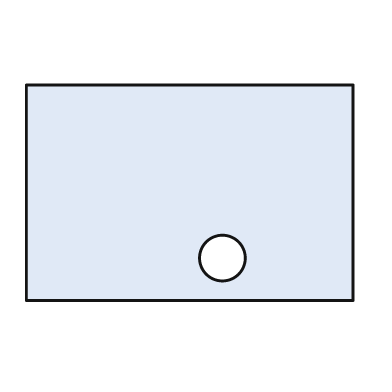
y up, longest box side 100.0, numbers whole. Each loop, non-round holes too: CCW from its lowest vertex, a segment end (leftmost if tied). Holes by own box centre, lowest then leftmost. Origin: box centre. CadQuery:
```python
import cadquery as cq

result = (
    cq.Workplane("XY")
    .moveTo(-50.0, -33.0)
    .lineTo(50.0, -33.0)
    .lineTo(50.0, 33.0)
    .lineTo(-50.0, 33.0)
    .close()
    .moveTo(10.0, -20.0)
    .circle(7.0)
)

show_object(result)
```